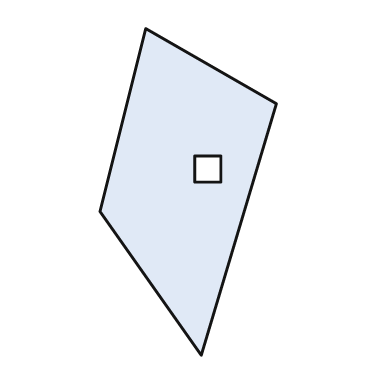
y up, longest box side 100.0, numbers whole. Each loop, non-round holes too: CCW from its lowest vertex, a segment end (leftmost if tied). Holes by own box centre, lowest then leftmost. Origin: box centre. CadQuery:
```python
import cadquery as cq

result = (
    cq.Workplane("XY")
    .moveTo(4.0, -50.0)
    .lineTo(27.0, 27.0)
    .lineTo(-13.0, 50.0)
    .lineTo(-27.0, -6.0)
    .close()
    .moveTo(2.0, 3.0)
    .lineTo(10.0, 3.0)
    .lineTo(10.0, 11.0)
    .lineTo(2.0, 11.0)
    .close()
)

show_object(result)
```